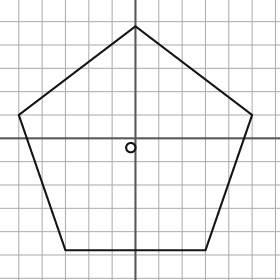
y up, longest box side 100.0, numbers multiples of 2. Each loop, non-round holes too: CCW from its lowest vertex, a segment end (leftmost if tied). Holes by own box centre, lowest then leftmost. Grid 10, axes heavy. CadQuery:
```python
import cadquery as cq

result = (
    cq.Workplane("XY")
    .moveTo(-30.0, -48.0)
    .lineTo(30.0, -48.0)
    .lineTo(50.0, 10.0)
    .lineTo(0.0, 48.0)
    .lineTo(-50.0, 10.0)
    .close()
    .moveTo(-2.0, -4.0)
    .circle(2.0)
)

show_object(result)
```